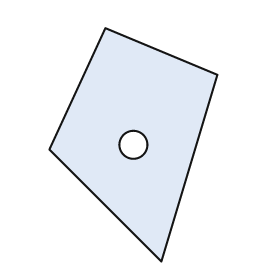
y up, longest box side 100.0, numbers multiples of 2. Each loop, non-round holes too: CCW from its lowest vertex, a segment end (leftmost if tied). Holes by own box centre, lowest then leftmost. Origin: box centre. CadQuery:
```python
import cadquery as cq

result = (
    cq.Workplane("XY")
    .moveTo(12.0, -50.0)
    .lineTo(36.0, 30.0)
    .lineTo(-12.0, 50.0)
    .lineTo(-36.0, -2.0)
    .close()
    .moveTo(0.0, 0.0)
    .circle(6.0)
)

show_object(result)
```